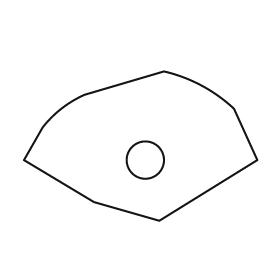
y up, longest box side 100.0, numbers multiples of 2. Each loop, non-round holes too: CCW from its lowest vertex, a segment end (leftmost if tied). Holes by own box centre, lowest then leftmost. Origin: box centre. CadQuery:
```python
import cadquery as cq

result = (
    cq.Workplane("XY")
    .moveTo(8.0, -32.0)
    .lineTo(50.0, -6.0)
    .lineTo(40.0, 16.0)
    .threePointArc((26.0, 26.0), (10.0, 32.0))
    .lineTo(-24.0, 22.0)
    .threePointArc((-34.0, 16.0), (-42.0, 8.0))
    .lineTo(-50.0, -6.0)
    .lineTo(-20.0, -24.0)
    .close()
    .moveTo(2.0, -6.0)
    .circle(8.0)
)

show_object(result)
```